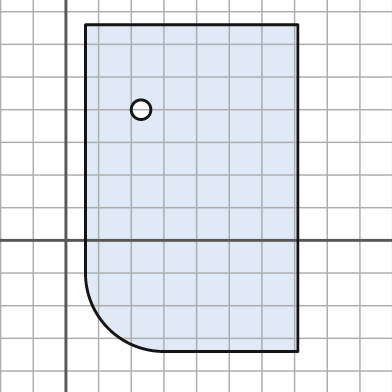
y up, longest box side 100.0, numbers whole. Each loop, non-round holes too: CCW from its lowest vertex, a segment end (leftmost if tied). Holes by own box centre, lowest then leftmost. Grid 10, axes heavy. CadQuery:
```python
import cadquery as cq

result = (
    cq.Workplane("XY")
    .moveTo(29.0, -34.0)
    .lineTo(71.0, -34.0)
    .lineTo(71.0, 66.0)
    .lineTo(6.0, 66.0)
    .lineTo(6.0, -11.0)
    .threePointArc((13.0, -27.0), (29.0, -34.0))
    .close()
    .moveTo(23.0, 40.0)
    .circle(3.0)
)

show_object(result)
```